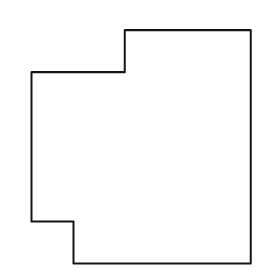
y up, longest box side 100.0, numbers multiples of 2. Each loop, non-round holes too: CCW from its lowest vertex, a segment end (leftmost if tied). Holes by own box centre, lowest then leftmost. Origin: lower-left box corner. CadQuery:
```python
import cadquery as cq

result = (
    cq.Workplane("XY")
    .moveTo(18.0, 0.0)
    .lineTo(94.0, 0.0)
    .lineTo(94.0, 100.0)
    .lineTo(40.0, 100.0)
    .lineTo(40.0, 82.0)
    .lineTo(0.0, 82.0)
    .lineTo(0.0, 18.0)
    .lineTo(18.0, 18.0)
    .close()
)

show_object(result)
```